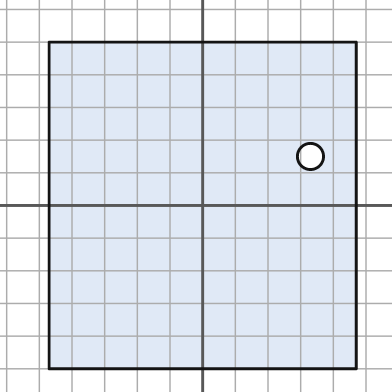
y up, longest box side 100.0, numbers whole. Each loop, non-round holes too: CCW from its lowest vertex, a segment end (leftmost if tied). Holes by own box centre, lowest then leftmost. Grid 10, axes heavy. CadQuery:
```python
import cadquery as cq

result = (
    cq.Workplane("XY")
    .moveTo(-47.0, -50.0)
    .lineTo(47.0, -50.0)
    .lineTo(47.0, 50.0)
    .lineTo(-47.0, 50.0)
    .close()
    .moveTo(33.0, 15.0)
    .circle(4.0)
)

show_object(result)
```